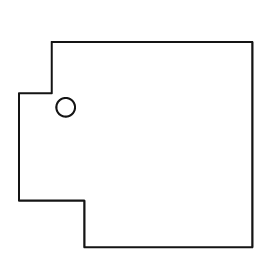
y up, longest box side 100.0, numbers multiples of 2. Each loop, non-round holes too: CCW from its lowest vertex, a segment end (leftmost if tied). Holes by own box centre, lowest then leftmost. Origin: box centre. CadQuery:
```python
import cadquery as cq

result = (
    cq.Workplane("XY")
    .moveTo(-22.0, -44.0)
    .lineTo(50.0, -44.0)
    .lineTo(50.0, 44.0)
    .lineTo(-36.0, 44.0)
    .lineTo(-36.0, 22.0)
    .lineTo(-50.0, 22.0)
    .lineTo(-50.0, -24.0)
    .lineTo(-22.0, -24.0)
    .close()
    .moveTo(-30.0, 16.0)
    .circle(4.0)
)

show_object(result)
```